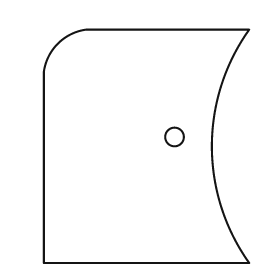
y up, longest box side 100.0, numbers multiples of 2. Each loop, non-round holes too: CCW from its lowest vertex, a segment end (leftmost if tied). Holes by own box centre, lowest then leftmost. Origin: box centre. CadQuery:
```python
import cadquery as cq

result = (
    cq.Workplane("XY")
    .moveTo(-44.0, -50.0)
    .lineTo(44.0, -50.0)
    .threePointArc((28.0, 0.0), (44.0, 50.0))
    .lineTo(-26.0, 50.0)
    .threePointArc((-38.0, 44.0), (-44.0, 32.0))
    .close()
    .moveTo(12.0, 4.0)
    .circle(4.0)
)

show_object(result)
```